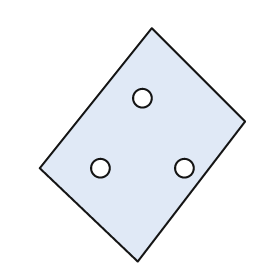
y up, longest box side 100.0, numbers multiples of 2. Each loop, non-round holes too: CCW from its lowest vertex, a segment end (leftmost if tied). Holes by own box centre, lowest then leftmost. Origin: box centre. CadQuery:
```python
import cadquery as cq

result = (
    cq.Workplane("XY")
    .moveTo(-2.0, -50.0)
    .lineTo(44.0, 10.0)
    .lineTo(4.0, 50.0)
    .lineTo(-44.0, -10.0)
    .close()
    .moveTo(-18.0, -10.0)
    .circle(4.0)
    .moveTo(18.0, -10.0)
    .circle(4.0)
    .moveTo(0.0, 20.0)
    .circle(4.0)
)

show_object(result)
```